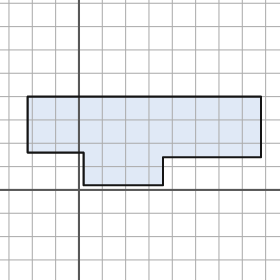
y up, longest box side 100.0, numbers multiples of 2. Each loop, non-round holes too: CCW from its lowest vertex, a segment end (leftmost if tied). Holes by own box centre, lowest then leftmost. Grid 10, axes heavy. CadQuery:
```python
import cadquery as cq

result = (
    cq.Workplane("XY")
    .moveTo(2.0, 2.0)
    .lineTo(36.0, 2.0)
    .lineTo(36.0, 14.0)
    .lineTo(78.0, 14.0)
    .lineTo(78.0, 40.0)
    .lineTo(-22.0, 40.0)
    .lineTo(-22.0, 16.0)
    .lineTo(2.0, 16.0)
    .close()
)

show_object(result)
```